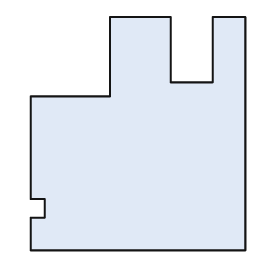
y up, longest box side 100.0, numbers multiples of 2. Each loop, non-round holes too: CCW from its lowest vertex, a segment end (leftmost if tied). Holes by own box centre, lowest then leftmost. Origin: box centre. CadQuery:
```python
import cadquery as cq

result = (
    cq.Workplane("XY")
    .moveTo(-46.0, -50.0)
    .lineTo(46.0, -50.0)
    .lineTo(46.0, 50.0)
    .lineTo(32.0, 50.0)
    .lineTo(32.0, 22.0)
    .lineTo(14.0, 22.0)
    .lineTo(14.0, 50.0)
    .lineTo(-12.0, 50.0)
    .lineTo(-12.0, 16.0)
    .lineTo(-46.0, 16.0)
    .lineTo(-46.0, -28.0)
    .lineTo(-40.0, -28.0)
    .lineTo(-40.0, -36.0)
    .lineTo(-46.0, -36.0)
    .close()
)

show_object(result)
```